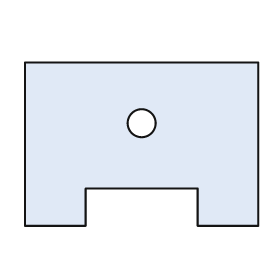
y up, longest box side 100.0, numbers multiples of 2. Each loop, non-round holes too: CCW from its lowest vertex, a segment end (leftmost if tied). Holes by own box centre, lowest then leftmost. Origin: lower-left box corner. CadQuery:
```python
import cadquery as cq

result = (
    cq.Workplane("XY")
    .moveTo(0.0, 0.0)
    .lineTo(26.0, 0.0)
    .lineTo(26.0, 16.0)
    .lineTo(74.0, 16.0)
    .lineTo(74.0, 0.0)
    .lineTo(100.0, 0.0)
    .lineTo(100.0, 70.0)
    .lineTo(0.0, 70.0)
    .close()
    .moveTo(50.0, 44.0)
    .circle(6.0)
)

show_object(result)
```